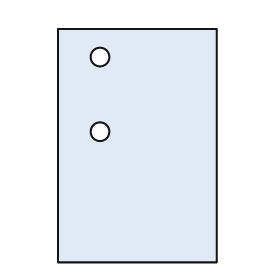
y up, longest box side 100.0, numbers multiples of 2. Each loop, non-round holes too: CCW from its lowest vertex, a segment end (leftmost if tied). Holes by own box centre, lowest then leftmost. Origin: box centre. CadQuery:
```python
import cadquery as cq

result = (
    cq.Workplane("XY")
    .moveTo(-34.0, -50.0)
    .lineTo(34.0, -50.0)
    .lineTo(34.0, 50.0)
    .lineTo(-34.0, 50.0)
    .close()
    .moveTo(-16.0, 6.0)
    .circle(4.0)
    .moveTo(-16.0, 38.0)
    .circle(4.0)
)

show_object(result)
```